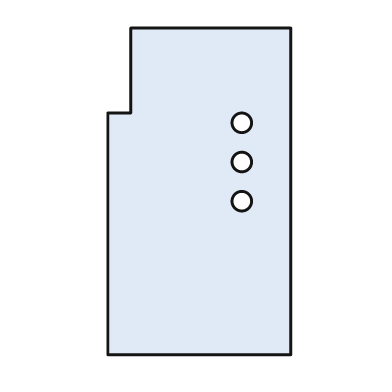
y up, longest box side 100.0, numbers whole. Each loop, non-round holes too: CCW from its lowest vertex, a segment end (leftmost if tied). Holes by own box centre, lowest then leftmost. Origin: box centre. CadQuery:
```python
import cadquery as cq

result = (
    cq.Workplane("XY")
    .moveTo(-28.0, -50.0)
    .lineTo(28.0, -50.0)
    .lineTo(28.0, 50.0)
    .lineTo(-21.0, 50.0)
    .lineTo(-21.0, 24.0)
    .lineTo(-28.0, 24.0)
    .close()
    .moveTo(13.0, -3.0)
    .circle(3.0)
    .moveTo(13.0, 9.0)
    .circle(3.0)
    .moveTo(13.0, 21.0)
    .circle(3.0)
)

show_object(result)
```